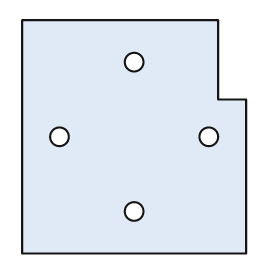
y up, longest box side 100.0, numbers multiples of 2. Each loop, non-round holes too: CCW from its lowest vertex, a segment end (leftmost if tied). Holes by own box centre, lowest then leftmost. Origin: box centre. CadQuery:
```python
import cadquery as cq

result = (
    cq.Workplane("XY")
    .moveTo(-48.0, -50.0)
    .lineTo(48.0, -50.0)
    .lineTo(48.0, 16.0)
    .lineTo(36.0, 16.0)
    .lineTo(36.0, 50.0)
    .lineTo(-48.0, 50.0)
    .close()
    .moveTo(0.0, -32.0)
    .circle(4.0)
    .moveTo(-32.0, 0.0)
    .circle(4.0)
    .moveTo(32.0, 0.0)
    .circle(4.0)
    .moveTo(0.0, 32.0)
    .circle(4.0)
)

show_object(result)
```